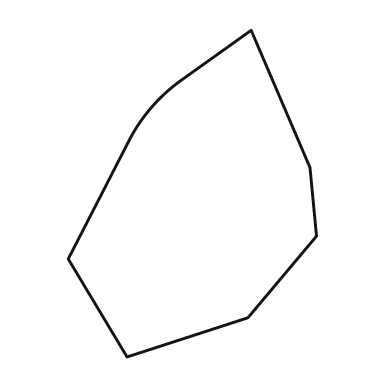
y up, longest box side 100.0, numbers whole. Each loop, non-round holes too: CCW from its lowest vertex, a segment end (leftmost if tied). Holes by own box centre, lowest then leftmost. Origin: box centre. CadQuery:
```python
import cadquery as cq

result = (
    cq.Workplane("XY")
    .moveTo(-20.0, -50.0)
    .lineTo(17.0, -38.0)
    .lineTo(38.0, -13.0)
    .lineTo(36.0, 8.0)
    .lineTo(18.0, 50.0)
    .lineTo(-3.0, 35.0)
    .threePointArc((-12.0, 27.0), (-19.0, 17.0))
    .lineTo(-38.0, -20.0)
    .close()
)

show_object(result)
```